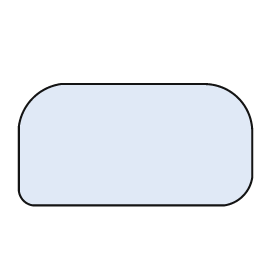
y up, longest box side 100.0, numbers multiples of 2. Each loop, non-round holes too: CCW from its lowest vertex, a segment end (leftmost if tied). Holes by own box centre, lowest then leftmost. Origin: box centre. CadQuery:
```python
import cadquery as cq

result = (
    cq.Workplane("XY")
    .moveTo(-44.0, -26.0)
    .lineTo(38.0, -26.0)
    .threePointArc((46.0, -22.0), (50.0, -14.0))
    .lineTo(50.0, 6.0)
    .threePointArc((44.0, 20.0), (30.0, 26.0))
    .lineTo(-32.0, 26.0)
    .threePointArc((-44.0, 20.0), (-50.0, 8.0))
    .lineTo(-50.0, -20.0)
    .threePointArc((-48.0, -24.0), (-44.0, -26.0))
    .close()
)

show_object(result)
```